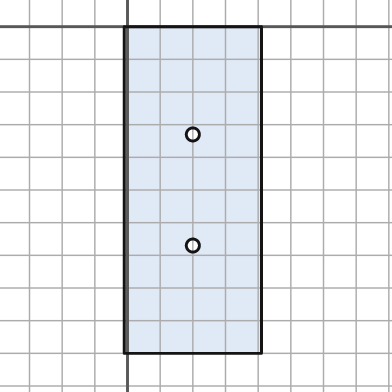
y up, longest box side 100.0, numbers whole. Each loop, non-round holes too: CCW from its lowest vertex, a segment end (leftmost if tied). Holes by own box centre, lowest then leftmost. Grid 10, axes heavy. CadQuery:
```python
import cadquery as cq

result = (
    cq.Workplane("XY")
    .moveTo(-1.0, -100.0)
    .lineTo(41.0, -100.0)
    .lineTo(41.0, 0.0)
    .lineTo(-1.0, 0.0)
    .close()
    .moveTo(20.0, -67.0)
    .circle(2.0)
    .moveTo(20.0, -33.0)
    .circle(2.0)
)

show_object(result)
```